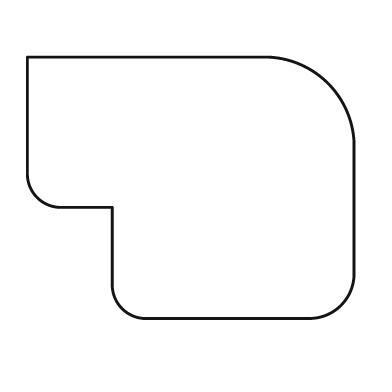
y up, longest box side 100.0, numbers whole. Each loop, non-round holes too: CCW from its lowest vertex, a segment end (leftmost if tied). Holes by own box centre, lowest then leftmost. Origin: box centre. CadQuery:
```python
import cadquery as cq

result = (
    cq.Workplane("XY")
    .moveTo(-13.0, -40.0)
    .lineTo(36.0, -40.0)
    .threePointArc((46.0, -36.0), (50.0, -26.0))
    .lineTo(50.0, 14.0)
    .threePointArc((42.0, 32.0), (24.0, 40.0))
    .lineTo(-50.0, 40.0)
    .lineTo(-50.0, 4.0)
    .threePointArc((-47.0, -3.0), (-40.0, -6.0))
    .lineTo(-24.0, -6.0)
    .lineTo(-24.0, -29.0)
    .threePointArc((-21.0, -37.0), (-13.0, -40.0))
    .close()
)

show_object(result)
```